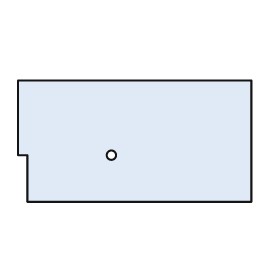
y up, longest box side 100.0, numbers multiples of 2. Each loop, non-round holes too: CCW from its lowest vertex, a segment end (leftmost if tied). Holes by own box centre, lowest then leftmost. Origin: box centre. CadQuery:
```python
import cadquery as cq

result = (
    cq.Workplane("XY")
    .moveTo(-46.0, -26.0)
    .lineTo(50.0, -26.0)
    .lineTo(50.0, 26.0)
    .lineTo(-50.0, 26.0)
    .lineTo(-50.0, -6.0)
    .lineTo(-46.0, -6.0)
    .close()
    .moveTo(-10.0, -6.0)
    .circle(2.0)
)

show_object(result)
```